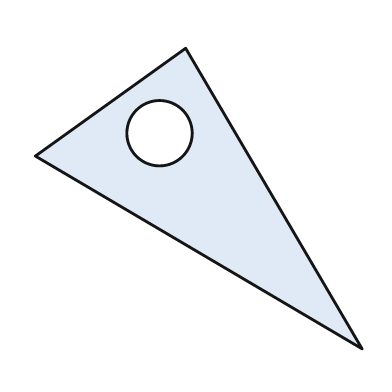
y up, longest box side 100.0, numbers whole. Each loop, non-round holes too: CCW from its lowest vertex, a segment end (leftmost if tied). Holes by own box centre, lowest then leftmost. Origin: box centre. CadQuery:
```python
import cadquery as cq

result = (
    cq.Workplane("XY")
    .moveTo(50.0, -46.0)
    .lineTo(-4.0, 46.0)
    .lineTo(-50.0, 13.0)
    .close()
    .moveTo(-12.0, 20.0)
    .circle(10.0)
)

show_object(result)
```